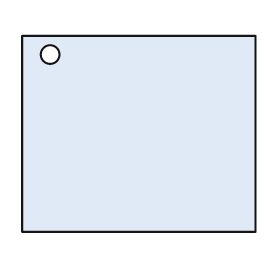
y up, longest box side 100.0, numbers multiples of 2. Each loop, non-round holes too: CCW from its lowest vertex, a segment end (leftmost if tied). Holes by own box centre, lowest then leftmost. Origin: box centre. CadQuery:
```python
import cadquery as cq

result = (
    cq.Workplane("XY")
    .moveTo(-50.0, -42.0)
    .lineTo(50.0, -42.0)
    .lineTo(50.0, 42.0)
    .lineTo(-50.0, 42.0)
    .close()
    .moveTo(-38.0, 34.0)
    .circle(4.0)
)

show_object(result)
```